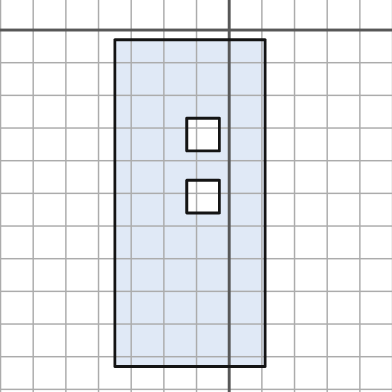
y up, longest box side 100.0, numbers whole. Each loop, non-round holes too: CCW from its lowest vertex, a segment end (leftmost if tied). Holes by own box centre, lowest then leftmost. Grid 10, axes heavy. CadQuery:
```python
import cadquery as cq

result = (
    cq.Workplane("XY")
    .moveTo(-35.0, -103.0)
    .lineTo(11.0, -103.0)
    .lineTo(11.0, -3.0)
    .lineTo(-35.0, -3.0)
    .close()
    .moveTo(-13.0, -56.0)
    .lineTo(-3.0, -56.0)
    .lineTo(-3.0, -46.0)
    .lineTo(-13.0, -46.0)
    .close()
    .moveTo(-13.0, -37.0)
    .lineTo(-3.0, -37.0)
    .lineTo(-3.0, -27.0)
    .lineTo(-13.0, -27.0)
    .close()
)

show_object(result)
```